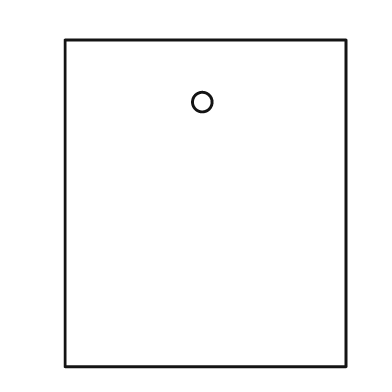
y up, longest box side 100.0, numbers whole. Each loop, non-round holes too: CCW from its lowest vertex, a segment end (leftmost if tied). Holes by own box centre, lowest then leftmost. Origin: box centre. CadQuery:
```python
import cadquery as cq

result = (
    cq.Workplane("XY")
    .moveTo(-43.0, -50.0)
    .lineTo(43.0, -50.0)
    .lineTo(43.0, 50.0)
    .lineTo(-43.0, 50.0)
    .close()
    .moveTo(-1.0, 31.0)
    .circle(3.0)
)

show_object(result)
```